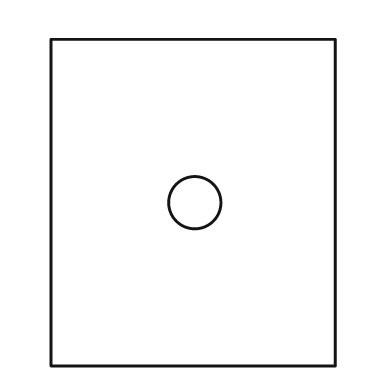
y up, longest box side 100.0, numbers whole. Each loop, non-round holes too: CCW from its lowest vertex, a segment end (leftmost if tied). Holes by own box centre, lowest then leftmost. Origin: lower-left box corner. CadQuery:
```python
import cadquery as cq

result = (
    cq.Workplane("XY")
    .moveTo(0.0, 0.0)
    .lineTo(87.0, 0.0)
    .lineTo(87.0, 100.0)
    .lineTo(0.0, 100.0)
    .close()
    .moveTo(44.0, 50.0)
    .circle(8.0)
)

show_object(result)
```